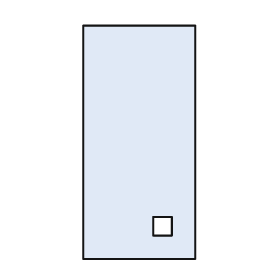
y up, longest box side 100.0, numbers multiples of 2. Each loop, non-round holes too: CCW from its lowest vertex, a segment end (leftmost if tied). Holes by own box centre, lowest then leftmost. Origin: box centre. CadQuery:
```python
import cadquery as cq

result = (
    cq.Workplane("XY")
    .moveTo(-24.0, -50.0)
    .lineTo(24.0, -50.0)
    .lineTo(24.0, 50.0)
    .lineTo(-24.0, 50.0)
    .close()
    .moveTo(6.0, -40.0)
    .lineTo(14.0, -40.0)
    .lineTo(14.0, -32.0)
    .lineTo(6.0, -32.0)
    .close()
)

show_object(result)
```